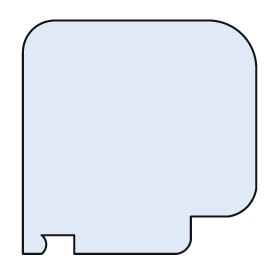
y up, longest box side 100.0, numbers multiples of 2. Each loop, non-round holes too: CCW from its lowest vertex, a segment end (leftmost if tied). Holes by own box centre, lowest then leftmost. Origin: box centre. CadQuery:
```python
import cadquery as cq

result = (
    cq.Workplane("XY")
    .moveTo(-50.0, -50.0)
    .lineTo(-42.0, -50.0)
    .threePointArc((-40.0, -46.0), (-42.0, -42.0))
    .lineTo(-28.0, -42.0)
    .lineTo(-28.0, -50.0)
    .lineTo(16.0, -50.0)
    .threePointArc((20.0, -48.0), (22.0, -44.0))
    .lineTo(22.0, -34.0)
    .lineTo(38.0, -34.0)
    .threePointArc((46.0, -30.0), (50.0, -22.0))
    .lineTo(50.0, 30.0)
    .threePointArc((44.0, 44.0), (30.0, 50.0))
    .lineTo(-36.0, 50.0)
    .threePointArc((-46.0, 46.0), (-50.0, 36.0))
    .close()
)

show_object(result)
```